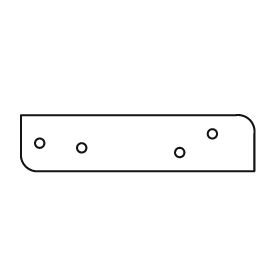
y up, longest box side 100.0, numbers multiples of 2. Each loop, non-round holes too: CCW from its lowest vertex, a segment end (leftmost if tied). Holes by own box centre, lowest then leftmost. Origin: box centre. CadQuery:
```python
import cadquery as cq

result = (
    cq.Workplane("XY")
    .moveTo(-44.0, -12.0)
    .lineTo(50.0, -12.0)
    .lineTo(50.0, 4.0)
    .threePointArc((48.0, 10.0), (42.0, 12.0))
    .lineTo(-50.0, 12.0)
    .lineTo(-50.0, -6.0)
    .threePointArc((-48.0, -10.0), (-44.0, -12.0))
    .close()
    .moveTo(18.0, -4.0)
    .circle(2.0)
    .moveTo(-24.0, -2.0)
    .circle(2.0)
    .moveTo(-42.0, 0.0)
    .circle(2.0)
    .moveTo(32.0, 4.0)
    .circle(2.0)
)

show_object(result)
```